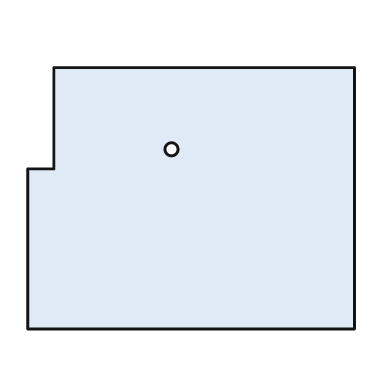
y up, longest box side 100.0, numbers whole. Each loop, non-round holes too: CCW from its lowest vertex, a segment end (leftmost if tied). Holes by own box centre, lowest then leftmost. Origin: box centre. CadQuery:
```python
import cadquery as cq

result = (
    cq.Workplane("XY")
    .moveTo(-50.0, -40.0)
    .lineTo(50.0, -40.0)
    .lineTo(50.0, 40.0)
    .lineTo(-42.0, 40.0)
    .lineTo(-42.0, 9.0)
    .lineTo(-50.0, 9.0)
    .close()
    .moveTo(-6.0, 15.0)
    .circle(2.0)
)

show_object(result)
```